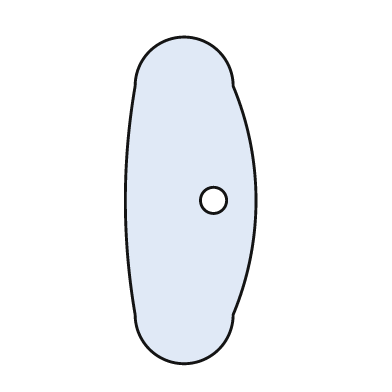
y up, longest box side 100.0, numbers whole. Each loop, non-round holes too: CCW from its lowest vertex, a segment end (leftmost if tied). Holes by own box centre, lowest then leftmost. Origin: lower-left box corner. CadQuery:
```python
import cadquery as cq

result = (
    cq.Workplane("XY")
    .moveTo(3.0, 15.0)
    .threePointArc((18.0, 0.0), (33.0, 15.0))
    .threePointArc((40.0, 50.0), (33.0, 85.0))
    .threePointArc((18.0, 100.0), (3.0, 85.0))
    .threePointArc((0.0, 50.0), (3.0, 15.0))
    .close()
    .moveTo(27.0, 50.0)
    .circle(4.0)
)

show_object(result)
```